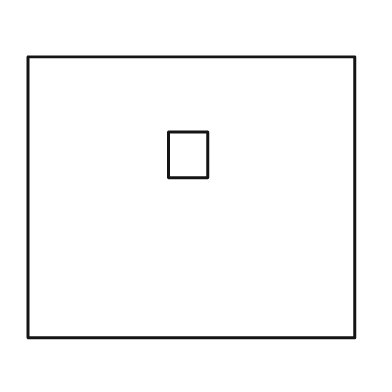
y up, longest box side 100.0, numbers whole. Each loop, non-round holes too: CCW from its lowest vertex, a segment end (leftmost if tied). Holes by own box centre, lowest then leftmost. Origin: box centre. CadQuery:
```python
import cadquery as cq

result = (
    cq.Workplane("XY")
    .moveTo(-50.0, -43.0)
    .lineTo(50.0, -43.0)
    .lineTo(50.0, 43.0)
    .lineTo(-50.0, 43.0)
    .close()
    .moveTo(-7.0, 6.0)
    .lineTo(5.0, 6.0)
    .lineTo(5.0, 20.0)
    .lineTo(-7.0, 20.0)
    .close()
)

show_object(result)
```